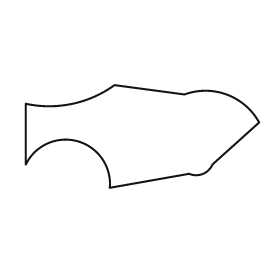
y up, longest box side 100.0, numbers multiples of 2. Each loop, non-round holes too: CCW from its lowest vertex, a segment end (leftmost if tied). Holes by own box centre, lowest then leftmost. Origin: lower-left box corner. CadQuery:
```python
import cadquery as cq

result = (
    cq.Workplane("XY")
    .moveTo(36.0, 0.0)
    .lineTo(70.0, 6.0)
    .threePointArc((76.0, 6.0), (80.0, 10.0))
    .lineTo(100.0, 28.0)
    .threePointArc((86.0, 40.0), (68.0, 40.0))
    .lineTo(38.0, 44.0)
    .threePointArc((20.0, 36.0), (0.0, 36.0))
    .lineTo(0.0, 10.0)
    .threePointArc((22.0, 20.0), (36.0, 0.0))
    .close()
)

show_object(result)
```